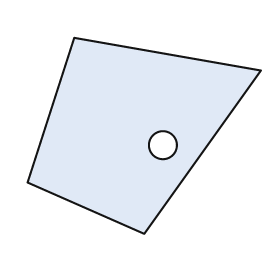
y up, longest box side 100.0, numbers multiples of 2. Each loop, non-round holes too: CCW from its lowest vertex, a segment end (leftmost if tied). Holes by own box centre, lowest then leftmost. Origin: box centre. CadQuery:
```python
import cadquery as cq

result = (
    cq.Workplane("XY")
    .moveTo(0.0, -42.0)
    .lineTo(50.0, 28.0)
    .lineTo(-30.0, 42.0)
    .lineTo(-50.0, -20.0)
    .close()
    .moveTo(8.0, -4.0)
    .circle(6.0)
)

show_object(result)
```